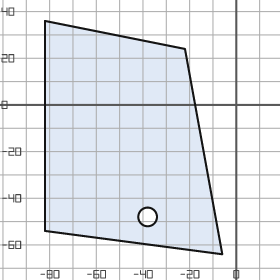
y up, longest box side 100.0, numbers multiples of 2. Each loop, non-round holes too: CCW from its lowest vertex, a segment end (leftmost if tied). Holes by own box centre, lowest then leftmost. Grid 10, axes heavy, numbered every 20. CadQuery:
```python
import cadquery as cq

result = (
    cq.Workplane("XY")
    .moveTo(-6.0, -64.0)
    .lineTo(-22.0, 24.0)
    .lineTo(-82.0, 36.0)
    .lineTo(-82.0, -54.0)
    .close()
    .moveTo(-38.0, -48.0)
    .circle(4.0)
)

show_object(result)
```